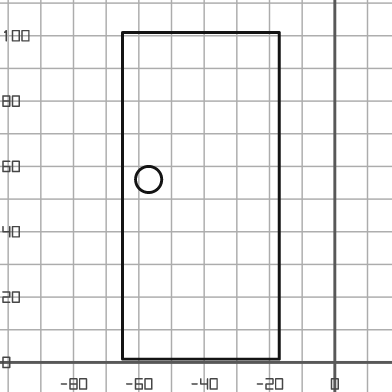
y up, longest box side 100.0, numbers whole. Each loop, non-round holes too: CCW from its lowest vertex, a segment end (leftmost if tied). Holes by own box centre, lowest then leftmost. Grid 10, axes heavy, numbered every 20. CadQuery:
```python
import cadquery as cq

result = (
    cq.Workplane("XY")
    .moveTo(-65.0, 1.0)
    .lineTo(-17.0, 1.0)
    .lineTo(-17.0, 101.0)
    .lineTo(-65.0, 101.0)
    .close()
    .moveTo(-57.0, 56.0)
    .circle(4.0)
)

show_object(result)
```